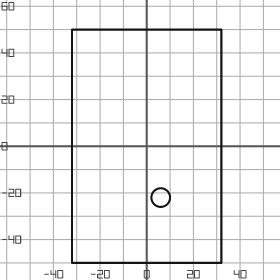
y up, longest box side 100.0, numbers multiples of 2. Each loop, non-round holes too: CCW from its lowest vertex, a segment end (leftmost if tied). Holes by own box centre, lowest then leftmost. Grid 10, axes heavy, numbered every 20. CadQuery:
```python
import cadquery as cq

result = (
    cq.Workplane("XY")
    .moveTo(-32.0, -50.0)
    .lineTo(32.0, -50.0)
    .lineTo(32.0, 50.0)
    .lineTo(-32.0, 50.0)
    .close()
    .moveTo(6.0, -22.0)
    .circle(4.0)
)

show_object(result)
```